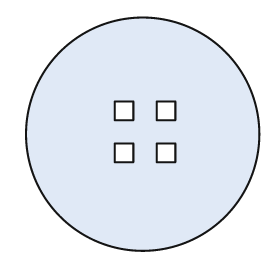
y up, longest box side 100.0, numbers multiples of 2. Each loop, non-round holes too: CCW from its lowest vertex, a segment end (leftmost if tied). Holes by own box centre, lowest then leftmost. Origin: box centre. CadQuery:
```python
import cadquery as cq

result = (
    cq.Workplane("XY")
    .moveTo(0.0, 0.0)
    .circle(50.0)
    .moveTo(-12.0, -12.0)
    .lineTo(-4.0, -12.0)
    .lineTo(-4.0, -4.0)
    .lineTo(-12.0, -4.0)
    .close()
    .moveTo(6.0, -12.0)
    .lineTo(14.0, -12.0)
    .lineTo(14.0, -4.0)
    .lineTo(6.0, -4.0)
    .close()
    .moveTo(-12.0, 6.0)
    .lineTo(-4.0, 6.0)
    .lineTo(-4.0, 14.0)
    .lineTo(-12.0, 14.0)
    .close()
    .moveTo(6.0, 6.0)
    .lineTo(14.0, 6.0)
    .lineTo(14.0, 14.0)
    .lineTo(6.0, 14.0)
    .close()
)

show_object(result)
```